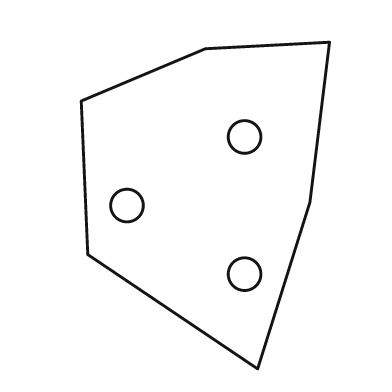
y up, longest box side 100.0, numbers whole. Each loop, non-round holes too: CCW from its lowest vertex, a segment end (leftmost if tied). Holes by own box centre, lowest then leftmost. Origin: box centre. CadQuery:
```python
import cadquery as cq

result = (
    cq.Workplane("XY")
    .moveTo(16.0, -50.0)
    .lineTo(32.0, 1.0)
    .lineTo(38.0, 50.0)
    .lineTo(0.0, 48.0)
    .lineTo(-38.0, 32.0)
    .lineTo(-36.0, -15.0)
    .close()
    .moveTo(12.0, -21.0)
    .circle(5.0)
    .moveTo(-24.0, 0.0)
    .circle(5.0)
    .moveTo(12.0, 21.0)
    .circle(5.0)
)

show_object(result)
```